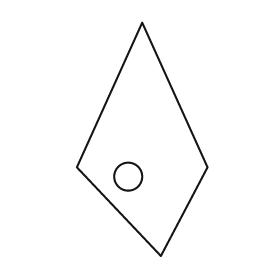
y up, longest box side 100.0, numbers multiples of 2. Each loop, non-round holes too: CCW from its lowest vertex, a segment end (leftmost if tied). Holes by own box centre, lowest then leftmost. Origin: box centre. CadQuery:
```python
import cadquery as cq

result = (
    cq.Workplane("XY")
    .moveTo(8.0, -50.0)
    .lineTo(28.0, -12.0)
    .lineTo(0.0, 50.0)
    .lineTo(-28.0, -12.0)
    .close()
    .moveTo(-6.0, -16.0)
    .circle(6.0)
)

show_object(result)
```